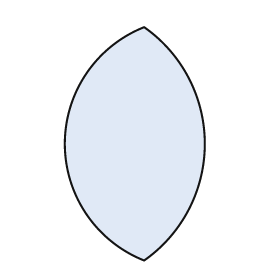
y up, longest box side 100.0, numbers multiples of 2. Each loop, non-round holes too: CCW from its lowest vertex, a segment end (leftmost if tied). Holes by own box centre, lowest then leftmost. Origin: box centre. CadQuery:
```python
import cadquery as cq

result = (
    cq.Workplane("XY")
    .moveTo(4.0, -50.0)
    .threePointArc((30.0, 0.0), (4.0, 50.0))
    .threePointArc((-30.0, 0.0), (4.0, -50.0))
    .close()
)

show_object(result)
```